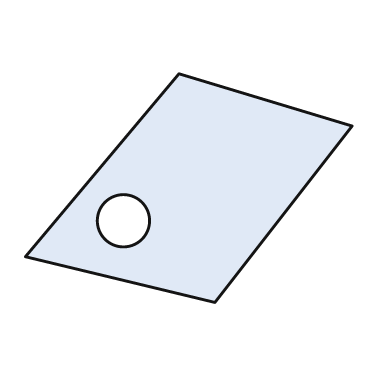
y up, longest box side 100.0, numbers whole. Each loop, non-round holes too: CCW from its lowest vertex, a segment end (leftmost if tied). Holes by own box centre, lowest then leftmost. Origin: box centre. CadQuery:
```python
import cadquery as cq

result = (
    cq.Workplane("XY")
    .moveTo(8.0, -35.0)
    .lineTo(50.0, 19.0)
    .lineTo(-3.0, 35.0)
    .lineTo(-50.0, -21.0)
    .close()
    .moveTo(-20.0, -10.0)
    .circle(8.0)
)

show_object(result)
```